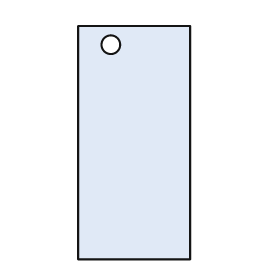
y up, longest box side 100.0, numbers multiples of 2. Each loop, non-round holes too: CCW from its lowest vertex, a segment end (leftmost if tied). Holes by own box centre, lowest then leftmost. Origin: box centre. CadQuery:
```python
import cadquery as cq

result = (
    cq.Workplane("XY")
    .moveTo(-24.0, -50.0)
    .lineTo(24.0, -50.0)
    .lineTo(24.0, 50.0)
    .lineTo(-24.0, 50.0)
    .close()
    .moveTo(-10.0, 42.0)
    .circle(4.0)
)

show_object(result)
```